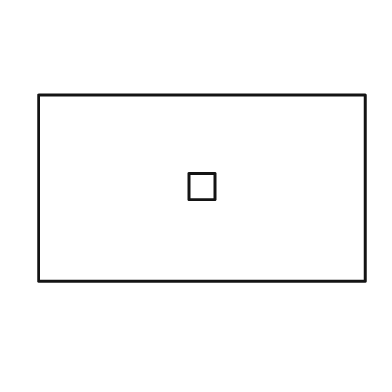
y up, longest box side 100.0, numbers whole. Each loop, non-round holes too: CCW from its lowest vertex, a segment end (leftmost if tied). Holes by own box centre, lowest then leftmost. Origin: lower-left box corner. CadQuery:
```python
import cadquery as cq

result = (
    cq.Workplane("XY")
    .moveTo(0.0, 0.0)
    .lineTo(100.0, 0.0)
    .lineTo(100.0, 57.0)
    .lineTo(0.0, 57.0)
    .close()
    .moveTo(46.0, 25.0)
    .lineTo(54.0, 25.0)
    .lineTo(54.0, 33.0)
    .lineTo(46.0, 33.0)
    .close()
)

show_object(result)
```